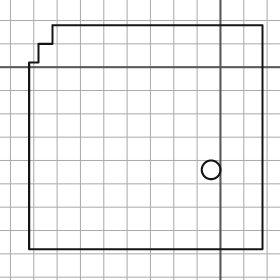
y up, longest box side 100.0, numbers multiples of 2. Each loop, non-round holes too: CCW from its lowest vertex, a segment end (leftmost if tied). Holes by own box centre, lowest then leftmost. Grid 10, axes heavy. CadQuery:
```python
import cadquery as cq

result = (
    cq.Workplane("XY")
    .moveTo(-82.0, -78.0)
    .lineTo(18.0, -78.0)
    .lineTo(18.0, 18.0)
    .lineTo(-72.0, 18.0)
    .lineTo(-72.0, 10.0)
    .lineTo(-78.0, 10.0)
    .lineTo(-78.0, 2.0)
    .lineTo(-82.0, 2.0)
    .close()
    .moveTo(-4.0, -44.0)
    .circle(4.0)
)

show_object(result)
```